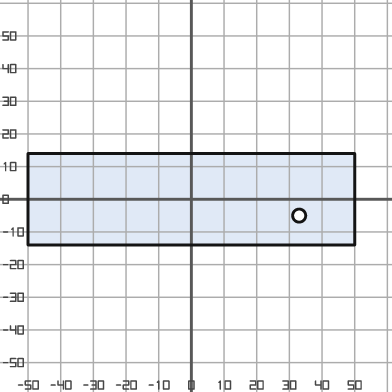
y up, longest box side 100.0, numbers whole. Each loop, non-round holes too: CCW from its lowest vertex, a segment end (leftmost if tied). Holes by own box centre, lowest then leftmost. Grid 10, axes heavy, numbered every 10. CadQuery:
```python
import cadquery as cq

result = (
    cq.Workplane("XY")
    .moveTo(-50.0, -14.0)
    .lineTo(50.0, -14.0)
    .lineTo(50.0, 14.0)
    .lineTo(-50.0, 14.0)
    .close()
    .moveTo(33.0, -5.0)
    .circle(2.0)
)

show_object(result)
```